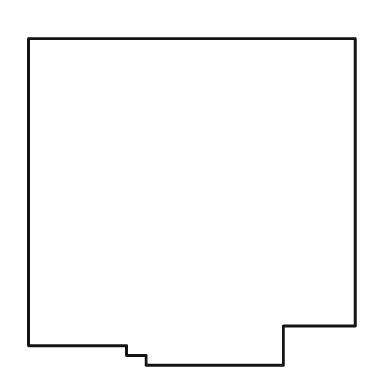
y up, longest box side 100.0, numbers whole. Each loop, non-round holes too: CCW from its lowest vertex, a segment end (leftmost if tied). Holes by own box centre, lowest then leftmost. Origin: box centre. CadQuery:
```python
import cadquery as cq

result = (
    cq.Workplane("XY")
    .moveTo(-14.0, -50.0)
    .lineTo(28.0, -50.0)
    .lineTo(28.0, -38.0)
    .lineTo(50.0, -38.0)
    .lineTo(50.0, 50.0)
    .lineTo(-50.0, 50.0)
    .lineTo(-50.0, -44.0)
    .lineTo(-20.0, -44.0)
    .lineTo(-20.0, -47.0)
    .lineTo(-14.0, -47.0)
    .close()
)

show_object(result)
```